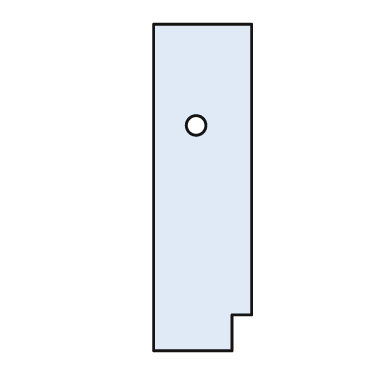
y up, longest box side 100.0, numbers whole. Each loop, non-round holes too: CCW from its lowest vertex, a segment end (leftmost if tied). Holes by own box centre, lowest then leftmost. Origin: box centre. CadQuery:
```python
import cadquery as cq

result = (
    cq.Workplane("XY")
    .moveTo(-15.0, -50.0)
    .lineTo(9.0, -50.0)
    .lineTo(9.0, -39.0)
    .lineTo(15.0, -39.0)
    .lineTo(15.0, 50.0)
    .lineTo(-15.0, 50.0)
    .close()
    .moveTo(-2.0, 19.0)
    .circle(3.0)
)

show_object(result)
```